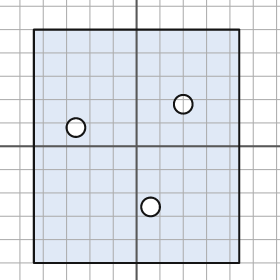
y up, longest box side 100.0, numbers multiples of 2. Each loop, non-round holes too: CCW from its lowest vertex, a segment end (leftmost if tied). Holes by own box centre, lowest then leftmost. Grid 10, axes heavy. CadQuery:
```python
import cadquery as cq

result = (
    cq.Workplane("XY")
    .moveTo(-44.0, -50.0)
    .lineTo(44.0, -50.0)
    .lineTo(44.0, 50.0)
    .lineTo(-44.0, 50.0)
    .close()
    .moveTo(6.0, -26.0)
    .circle(4.0)
    .moveTo(-26.0, 8.0)
    .circle(4.0)
    .moveTo(20.0, 18.0)
    .circle(4.0)
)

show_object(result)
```